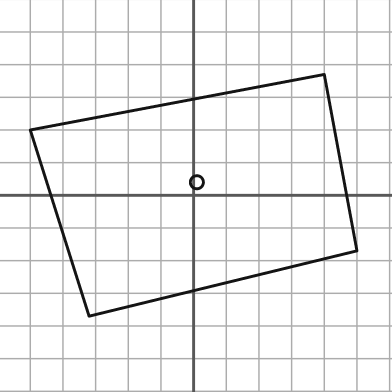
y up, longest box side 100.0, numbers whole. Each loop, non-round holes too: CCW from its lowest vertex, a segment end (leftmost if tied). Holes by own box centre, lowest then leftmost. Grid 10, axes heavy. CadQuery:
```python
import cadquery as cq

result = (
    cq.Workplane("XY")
    .moveTo(-32.0, -37.0)
    .lineTo(50.0, -17.0)
    .lineTo(40.0, 37.0)
    .lineTo(-50.0, 20.0)
    .close()
    .moveTo(1.0, 4.0)
    .circle(2.0)
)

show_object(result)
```